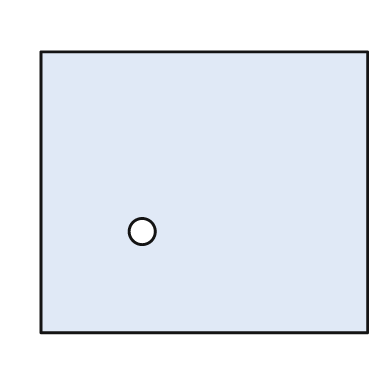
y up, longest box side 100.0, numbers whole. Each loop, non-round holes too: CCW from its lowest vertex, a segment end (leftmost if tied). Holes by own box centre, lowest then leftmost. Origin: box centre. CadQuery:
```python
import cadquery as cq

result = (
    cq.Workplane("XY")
    .moveTo(-50.0, -43.0)
    .lineTo(50.0, -43.0)
    .lineTo(50.0, 43.0)
    .lineTo(-50.0, 43.0)
    .close()
    .moveTo(-19.0, -12.0)
    .circle(4.0)
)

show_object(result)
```